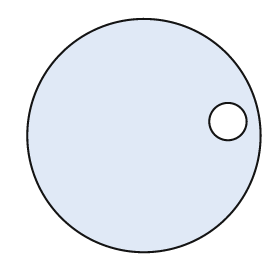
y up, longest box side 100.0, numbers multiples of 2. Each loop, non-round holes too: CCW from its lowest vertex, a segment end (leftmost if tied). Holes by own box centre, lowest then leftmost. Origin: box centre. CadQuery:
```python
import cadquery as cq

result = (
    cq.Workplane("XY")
    .moveTo(0.0, 0.0)
    .circle(50.0)
    .moveTo(36.0, 6.0)
    .circle(8.0)
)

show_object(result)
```